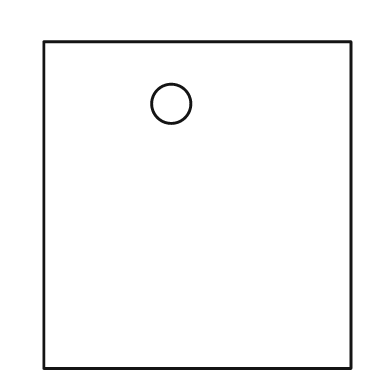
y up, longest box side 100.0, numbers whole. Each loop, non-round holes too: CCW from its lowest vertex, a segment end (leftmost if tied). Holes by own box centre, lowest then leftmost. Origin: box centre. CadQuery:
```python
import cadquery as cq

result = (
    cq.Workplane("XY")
    .moveTo(-47.0, -50.0)
    .lineTo(47.0, -50.0)
    .lineTo(47.0, 50.0)
    .lineTo(-47.0, 50.0)
    .close()
    .moveTo(-8.0, 31.0)
    .circle(6.0)
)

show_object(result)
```